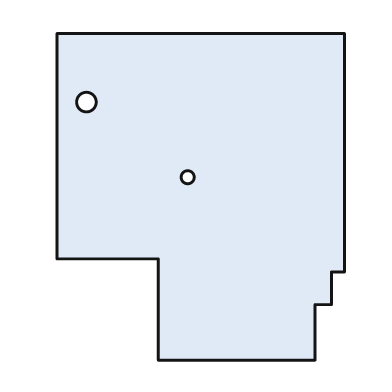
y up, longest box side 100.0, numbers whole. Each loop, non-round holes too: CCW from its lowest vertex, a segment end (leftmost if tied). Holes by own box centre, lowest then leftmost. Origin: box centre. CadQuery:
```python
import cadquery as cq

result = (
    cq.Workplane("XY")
    .moveTo(-13.0, -50.0)
    .lineTo(35.0, -50.0)
    .lineTo(35.0, -33.0)
    .lineTo(40.0, -33.0)
    .lineTo(40.0, -23.0)
    .lineTo(44.0, -23.0)
    .lineTo(44.0, 50.0)
    .lineTo(-44.0, 50.0)
    .lineTo(-44.0, -19.0)
    .lineTo(-13.0, -19.0)
    .close()
    .moveTo(-4.0, 6.0)
    .circle(2.0)
    .moveTo(-35.0, 29.0)
    .circle(3.0)
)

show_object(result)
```